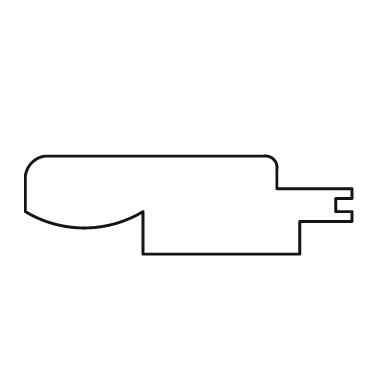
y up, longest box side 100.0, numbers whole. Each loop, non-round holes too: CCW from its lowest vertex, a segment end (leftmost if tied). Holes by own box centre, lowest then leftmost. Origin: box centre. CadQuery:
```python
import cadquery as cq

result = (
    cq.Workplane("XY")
    .moveTo(-14.0, -15.0)
    .lineTo(34.0, -15.0)
    .lineTo(34.0, -5.0)
    .lineTo(50.0, -5.0)
    .lineTo(50.0, -2.0)
    .lineTo(45.0, -2.0)
    .lineTo(45.0, 2.0)
    .lineTo(50.0, 2.0)
    .lineTo(50.0, 5.0)
    .lineTo(27.0, 5.0)
    .lineTo(27.0, 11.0)
    .threePointArc((26.0, 14.0), (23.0, 15.0))
    .lineTo(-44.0, 15.0)
    .threePointArc((-48.0, 13.0), (-50.0, 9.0))
    .lineTo(-50.0, -2.0)
    .threePointArc((-32.0, -7.0), (-14.0, -2.0))
    .close()
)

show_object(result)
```